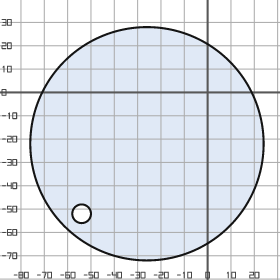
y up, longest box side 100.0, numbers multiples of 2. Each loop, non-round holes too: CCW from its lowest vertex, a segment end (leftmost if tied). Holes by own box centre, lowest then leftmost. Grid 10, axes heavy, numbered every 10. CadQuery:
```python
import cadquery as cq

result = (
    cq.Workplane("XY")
    .moveTo(-26.0, -22.0)
    .circle(50.0)
    .moveTo(-54.0, -52.0)
    .circle(4.0)
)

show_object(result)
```